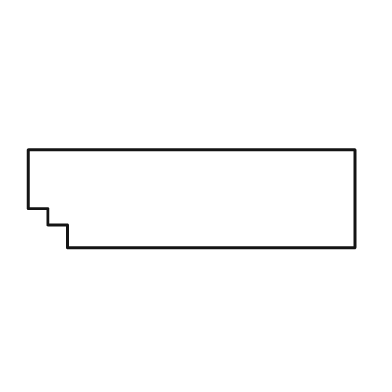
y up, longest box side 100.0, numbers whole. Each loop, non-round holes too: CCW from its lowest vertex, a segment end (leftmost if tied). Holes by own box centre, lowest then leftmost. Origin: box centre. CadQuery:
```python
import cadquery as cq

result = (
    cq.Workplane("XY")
    .moveTo(-38.0, -15.0)
    .lineTo(50.0, -15.0)
    .lineTo(50.0, 15.0)
    .lineTo(-50.0, 15.0)
    .lineTo(-50.0, -3.0)
    .lineTo(-44.0, -3.0)
    .lineTo(-44.0, -8.0)
    .lineTo(-38.0, -8.0)
    .close()
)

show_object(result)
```